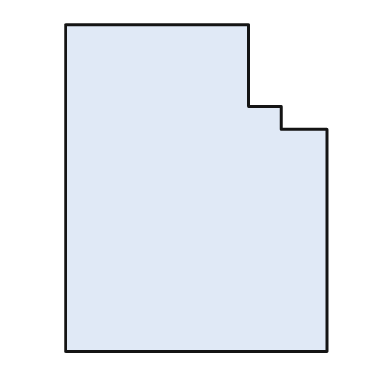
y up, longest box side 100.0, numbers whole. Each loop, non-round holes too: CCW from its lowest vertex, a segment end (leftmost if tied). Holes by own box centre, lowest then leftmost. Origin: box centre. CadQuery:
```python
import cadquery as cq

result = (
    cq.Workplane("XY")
    .moveTo(-40.0, -50.0)
    .lineTo(40.0, -50.0)
    .lineTo(40.0, 18.0)
    .lineTo(26.0, 18.0)
    .lineTo(26.0, 25.0)
    .lineTo(16.0, 25.0)
    .lineTo(16.0, 50.0)
    .lineTo(-40.0, 50.0)
    .close()
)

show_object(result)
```